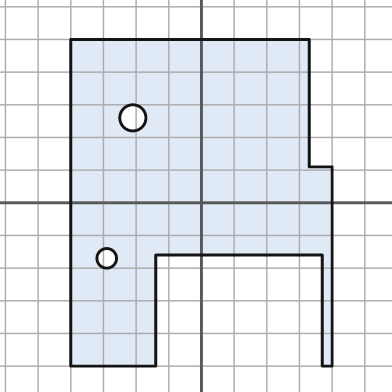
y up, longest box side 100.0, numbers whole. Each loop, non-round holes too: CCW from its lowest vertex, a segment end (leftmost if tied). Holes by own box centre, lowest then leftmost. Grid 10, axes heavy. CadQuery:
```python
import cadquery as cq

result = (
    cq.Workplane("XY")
    .moveTo(-40.0, -50.0)
    .lineTo(-14.0, -50.0)
    .lineTo(-14.0, -16.0)
    .lineTo(37.0, -16.0)
    .lineTo(37.0, -50.0)
    .lineTo(40.0, -50.0)
    .lineTo(40.0, 11.0)
    .lineTo(33.0, 11.0)
    .lineTo(33.0, 50.0)
    .lineTo(-40.0, 50.0)
    .close()
    .moveTo(-29.0, -17.0)
    .circle(3.0)
    .moveTo(-21.0, 26.0)
    .circle(4.0)
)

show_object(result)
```